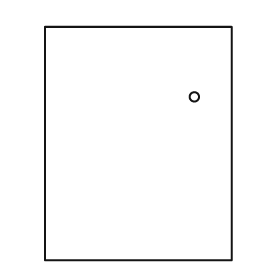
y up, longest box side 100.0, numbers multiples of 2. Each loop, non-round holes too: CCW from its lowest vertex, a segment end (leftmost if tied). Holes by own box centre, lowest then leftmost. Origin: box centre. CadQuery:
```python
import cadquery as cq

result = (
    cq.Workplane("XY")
    .moveTo(-40.0, -50.0)
    .lineTo(40.0, -50.0)
    .lineTo(40.0, 50.0)
    .lineTo(-40.0, 50.0)
    .close()
    .moveTo(24.0, 20.0)
    .circle(2.0)
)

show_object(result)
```